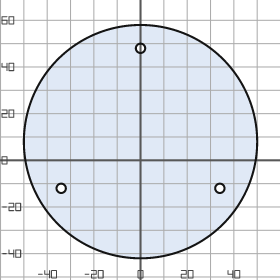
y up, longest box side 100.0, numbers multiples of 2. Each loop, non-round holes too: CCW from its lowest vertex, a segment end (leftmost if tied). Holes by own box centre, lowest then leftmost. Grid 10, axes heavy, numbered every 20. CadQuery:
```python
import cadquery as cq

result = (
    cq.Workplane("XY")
    .moveTo(0.0, 8.0)
    .circle(50.0)
    .moveTo(-34.0, -12.0)
    .circle(2.0)
    .moveTo(34.0, -12.0)
    .circle(2.0)
    .moveTo(0.0, 48.0)
    .circle(2.0)
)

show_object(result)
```